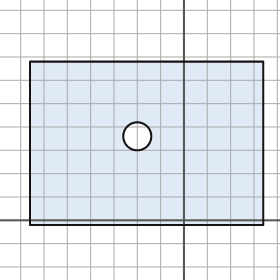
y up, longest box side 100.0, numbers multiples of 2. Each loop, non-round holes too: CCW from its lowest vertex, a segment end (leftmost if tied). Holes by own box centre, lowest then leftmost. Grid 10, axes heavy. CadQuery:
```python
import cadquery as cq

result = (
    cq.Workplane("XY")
    .moveTo(-66.0, -2.0)
    .lineTo(34.0, -2.0)
    .lineTo(34.0, 68.0)
    .lineTo(-66.0, 68.0)
    .close()
    .moveTo(-20.0, 36.0)
    .circle(6.0)
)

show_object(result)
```